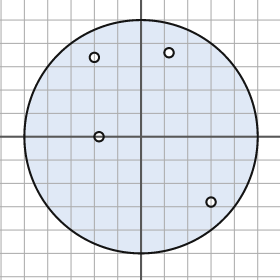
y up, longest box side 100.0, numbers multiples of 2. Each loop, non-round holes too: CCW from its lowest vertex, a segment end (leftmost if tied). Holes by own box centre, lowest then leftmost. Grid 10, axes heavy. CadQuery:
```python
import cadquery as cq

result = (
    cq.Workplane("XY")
    .moveTo(0.0, 0.0)
    .circle(50.0)
    .moveTo(30.0, -28.0)
    .circle(2.0)
    .moveTo(-18.0, 0.0)
    .circle(2.0)
    .moveTo(-20.0, 34.0)
    .circle(2.0)
    .moveTo(12.0, 36.0)
    .circle(2.0)
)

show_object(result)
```